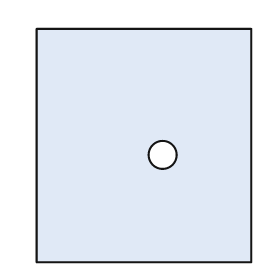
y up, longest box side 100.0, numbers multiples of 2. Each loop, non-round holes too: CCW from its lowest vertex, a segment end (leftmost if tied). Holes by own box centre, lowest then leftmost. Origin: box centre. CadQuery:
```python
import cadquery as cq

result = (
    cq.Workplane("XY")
    .moveTo(-46.0, -50.0)
    .lineTo(46.0, -50.0)
    .lineTo(46.0, 50.0)
    .lineTo(-46.0, 50.0)
    .close()
    .moveTo(8.0, -4.0)
    .circle(6.0)
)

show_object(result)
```